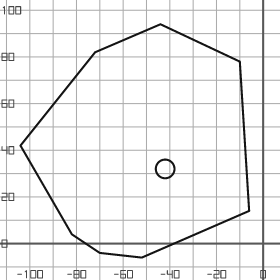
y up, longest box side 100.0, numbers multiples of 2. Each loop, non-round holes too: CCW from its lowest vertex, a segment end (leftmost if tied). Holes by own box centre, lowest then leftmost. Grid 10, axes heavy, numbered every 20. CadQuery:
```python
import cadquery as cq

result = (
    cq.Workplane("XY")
    .moveTo(-52.0, -6.0)
    .lineTo(-6.0, 14.0)
    .lineTo(-10.0, 78.0)
    .lineTo(-44.0, 94.0)
    .lineTo(-72.0, 82.0)
    .lineTo(-104.0, 42.0)
    .lineTo(-82.0, 4.0)
    .lineTo(-70.0, -4.0)
    .close()
    .moveTo(-42.0, 32.0)
    .circle(4.0)
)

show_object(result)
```